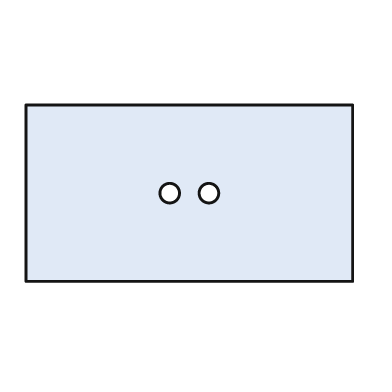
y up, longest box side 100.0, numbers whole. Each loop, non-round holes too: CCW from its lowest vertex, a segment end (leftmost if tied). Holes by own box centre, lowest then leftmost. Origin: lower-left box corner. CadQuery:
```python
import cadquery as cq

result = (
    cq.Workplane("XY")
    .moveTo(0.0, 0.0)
    .lineTo(100.0, 0.0)
    .lineTo(100.0, 54.0)
    .lineTo(0.0, 54.0)
    .close()
    .moveTo(44.0, 27.0)
    .circle(3.0)
    .moveTo(56.0, 27.0)
    .circle(3.0)
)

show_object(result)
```